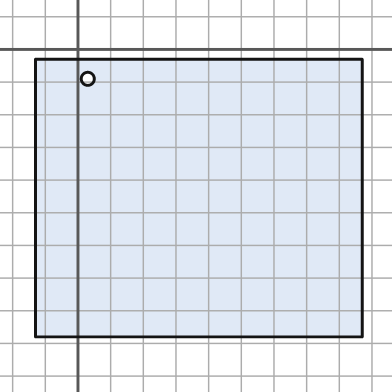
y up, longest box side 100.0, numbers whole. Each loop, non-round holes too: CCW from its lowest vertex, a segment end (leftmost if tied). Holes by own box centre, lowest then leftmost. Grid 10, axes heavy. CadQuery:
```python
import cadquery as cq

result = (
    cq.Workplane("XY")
    .moveTo(-13.0, -88.0)
    .lineTo(87.0, -88.0)
    .lineTo(87.0, -3.0)
    .lineTo(-13.0, -3.0)
    .close()
    .moveTo(3.0, -9.0)
    .circle(2.0)
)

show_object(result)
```